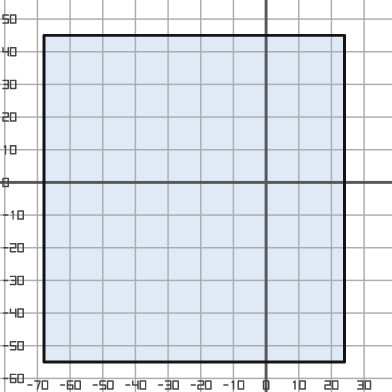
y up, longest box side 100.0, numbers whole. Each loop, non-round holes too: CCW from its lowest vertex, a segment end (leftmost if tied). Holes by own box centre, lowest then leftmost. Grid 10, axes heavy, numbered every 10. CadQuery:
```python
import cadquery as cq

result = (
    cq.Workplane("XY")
    .moveTo(-68.0, -55.0)
    .lineTo(24.0, -55.0)
    .lineTo(24.0, 45.0)
    .lineTo(-68.0, 45.0)
    .close()
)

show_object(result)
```